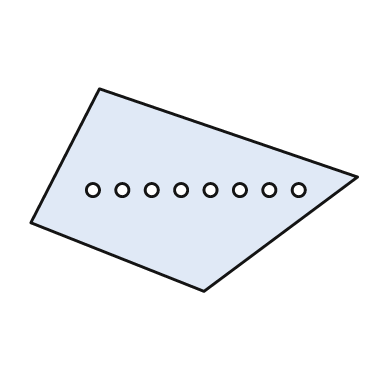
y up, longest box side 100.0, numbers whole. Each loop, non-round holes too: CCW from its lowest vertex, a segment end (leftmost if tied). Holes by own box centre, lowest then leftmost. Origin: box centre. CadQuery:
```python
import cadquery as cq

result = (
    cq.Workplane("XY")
    .moveTo(3.0, -31.0)
    .lineTo(50.0, 4.0)
    .lineTo(-29.0, 31.0)
    .lineTo(-50.0, -10.0)
    .close()
    .moveTo(-31.0, 0.0)
    .circle(2.0)
    .moveTo(-22.0, 0.0)
    .circle(2.0)
    .moveTo(-13.0, 0.0)
    .circle(2.0)
    .moveTo(-4.0, 0.0)
    .circle(2.0)
    .moveTo(5.0, 0.0)
    .circle(2.0)
    .moveTo(14.0, 0.0)
    .circle(2.0)
    .moveTo(23.0, 0.0)
    .circle(2.0)
    .moveTo(32.0, 0.0)
    .circle(2.0)
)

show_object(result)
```